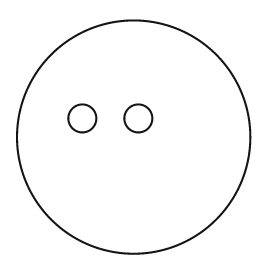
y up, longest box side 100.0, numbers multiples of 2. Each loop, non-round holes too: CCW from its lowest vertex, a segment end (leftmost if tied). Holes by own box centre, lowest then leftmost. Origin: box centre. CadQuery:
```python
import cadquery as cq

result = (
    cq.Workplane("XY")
    .moveTo(0.0, 0.0)
    .circle(50.0)
    .moveTo(-22.0, 8.0)
    .circle(6.0)
    .moveTo(2.0, 8.0)
    .circle(6.0)
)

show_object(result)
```